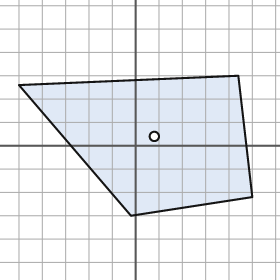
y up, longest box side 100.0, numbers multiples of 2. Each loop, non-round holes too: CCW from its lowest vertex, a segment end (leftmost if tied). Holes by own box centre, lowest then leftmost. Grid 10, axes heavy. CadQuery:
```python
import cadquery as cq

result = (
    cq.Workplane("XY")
    .moveTo(-2.0, -30.0)
    .lineTo(50.0, -22.0)
    .lineTo(44.0, 30.0)
    .lineTo(-50.0, 26.0)
    .close()
    .moveTo(8.0, 4.0)
    .circle(2.0)
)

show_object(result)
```